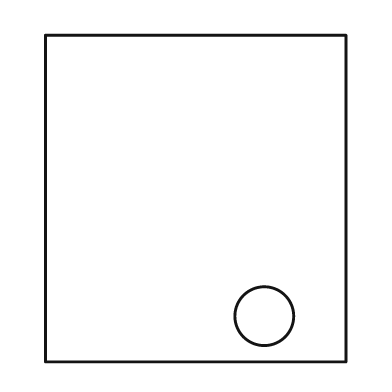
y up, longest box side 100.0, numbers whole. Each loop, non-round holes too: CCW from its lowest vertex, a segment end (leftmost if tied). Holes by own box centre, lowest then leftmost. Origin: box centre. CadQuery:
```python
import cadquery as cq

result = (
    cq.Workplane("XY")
    .moveTo(-46.0, -50.0)
    .lineTo(46.0, -50.0)
    .lineTo(46.0, 50.0)
    .lineTo(-46.0, 50.0)
    .close()
    .moveTo(21.0, -36.0)
    .circle(9.0)
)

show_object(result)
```